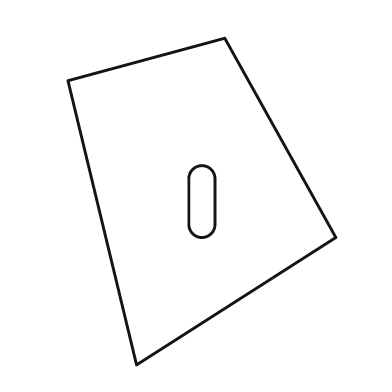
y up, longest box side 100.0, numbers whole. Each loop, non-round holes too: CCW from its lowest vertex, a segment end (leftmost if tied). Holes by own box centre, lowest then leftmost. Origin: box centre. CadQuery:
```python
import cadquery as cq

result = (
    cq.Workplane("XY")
    .moveTo(-20.0, -50.0)
    .lineTo(41.0, -11.0)
    .lineTo(7.0, 50.0)
    .lineTo(-41.0, 37.0)
    .close()
    .moveTo(-4.0, -7.0)
    .threePointArc((0.0, -11.0), (4.0, -7.0))
    .lineTo(4.0, 7.0)
    .threePointArc((0.0, 11.0), (-4.0, 7.0))
    .close()
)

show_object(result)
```